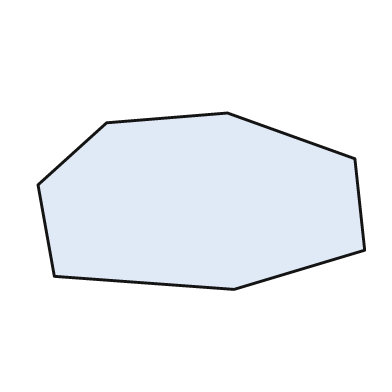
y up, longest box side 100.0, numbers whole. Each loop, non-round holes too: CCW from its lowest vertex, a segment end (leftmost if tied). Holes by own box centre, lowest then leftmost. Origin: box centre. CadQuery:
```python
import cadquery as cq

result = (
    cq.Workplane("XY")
    .moveTo(10.0, -27.0)
    .lineTo(50.0, -15.0)
    .lineTo(47.0, 13.0)
    .lineTo(8.0, 27.0)
    .lineTo(-29.0, 24.0)
    .lineTo(-50.0, 5.0)
    .lineTo(-45.0, -23.0)
    .close()
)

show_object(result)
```